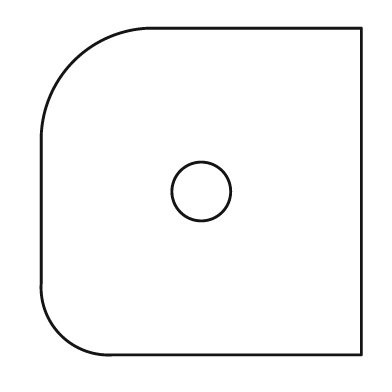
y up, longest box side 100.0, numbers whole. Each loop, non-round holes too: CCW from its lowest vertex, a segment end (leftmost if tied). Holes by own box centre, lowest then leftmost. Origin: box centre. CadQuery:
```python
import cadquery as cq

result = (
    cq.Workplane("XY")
    .moveTo(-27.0, -50.0)
    .lineTo(49.0, -50.0)
    .lineTo(49.0, 50.0)
    .lineTo(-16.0, 50.0)
    .threePointArc((-39.0, 40.0), (-49.0, 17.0))
    .lineTo(-49.0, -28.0)
    .threePointArc((-43.0, -44.0), (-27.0, -50.0))
    .close()
    .moveTo(0.0, 0.0)
    .circle(9.0)
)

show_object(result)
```